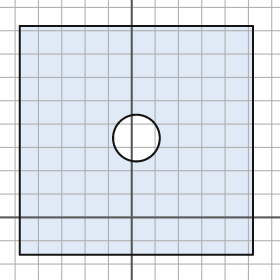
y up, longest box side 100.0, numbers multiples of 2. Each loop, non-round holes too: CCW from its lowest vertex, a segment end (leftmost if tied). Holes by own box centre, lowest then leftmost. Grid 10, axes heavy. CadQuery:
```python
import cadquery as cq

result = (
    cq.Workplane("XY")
    .moveTo(-48.0, -16.0)
    .lineTo(52.0, -16.0)
    .lineTo(52.0, 82.0)
    .lineTo(-48.0, 82.0)
    .close()
    .moveTo(2.0, 34.0)
    .circle(10.0)
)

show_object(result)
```